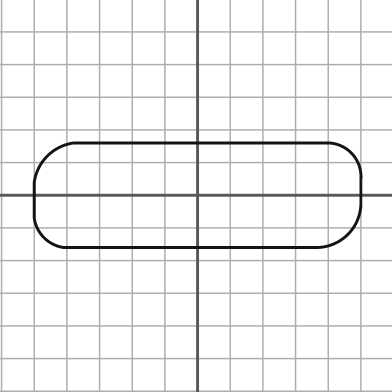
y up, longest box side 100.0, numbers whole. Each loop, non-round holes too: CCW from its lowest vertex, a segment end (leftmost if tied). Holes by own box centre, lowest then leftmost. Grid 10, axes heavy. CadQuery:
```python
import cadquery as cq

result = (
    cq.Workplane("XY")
    .moveTo(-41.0, -16.0)
    .lineTo(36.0, -16.0)
    .threePointArc((46.0, -12.0), (50.0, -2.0))
    .lineTo(50.0, 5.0)
    .threePointArc((47.0, 13.0), (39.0, 16.0))
    .lineTo(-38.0, 16.0)
    .threePointArc((-46.0, 12.0), (-50.0, 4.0))
    .lineTo(-50.0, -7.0)
    .threePointArc((-47.0, -13.0), (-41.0, -16.0))
    .close()
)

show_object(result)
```